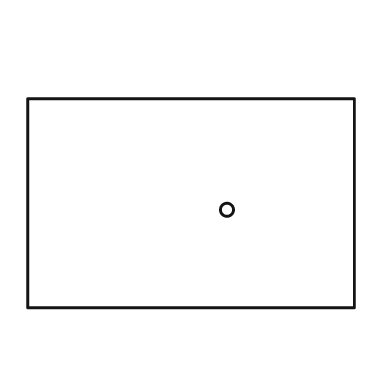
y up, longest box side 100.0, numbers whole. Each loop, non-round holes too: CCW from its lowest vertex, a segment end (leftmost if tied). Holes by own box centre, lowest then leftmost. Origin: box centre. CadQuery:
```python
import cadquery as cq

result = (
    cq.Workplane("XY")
    .moveTo(-50.0, -32.0)
    .lineTo(50.0, -32.0)
    .lineTo(50.0, 32.0)
    .lineTo(-50.0, 32.0)
    .close()
    .moveTo(11.0, -2.0)
    .circle(2.0)
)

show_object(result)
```